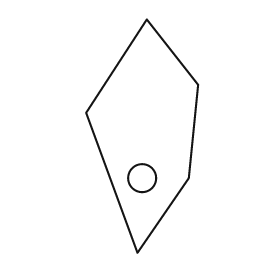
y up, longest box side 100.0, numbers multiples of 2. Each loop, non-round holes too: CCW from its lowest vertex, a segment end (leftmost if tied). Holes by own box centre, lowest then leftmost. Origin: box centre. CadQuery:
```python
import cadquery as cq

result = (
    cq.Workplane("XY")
    .moveTo(-2.0, -50.0)
    .lineTo(20.0, -18.0)
    .lineTo(24.0, 22.0)
    .lineTo(2.0, 50.0)
    .lineTo(-24.0, 10.0)
    .close()
    .moveTo(0.0, -18.0)
    .circle(6.0)
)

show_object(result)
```